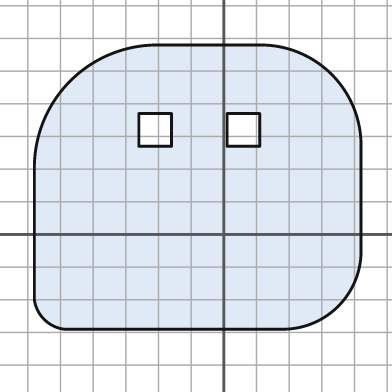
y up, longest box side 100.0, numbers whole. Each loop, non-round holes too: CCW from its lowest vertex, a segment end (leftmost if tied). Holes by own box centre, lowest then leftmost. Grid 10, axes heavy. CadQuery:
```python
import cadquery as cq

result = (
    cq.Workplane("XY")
    .moveTo(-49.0, -29.0)
    .lineTo(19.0, -29.0)
    .threePointArc((35.0, -22.0), (42.0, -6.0))
    .lineTo(42.0, 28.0)
    .threePointArc((33.0, 49.0), (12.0, 58.0))
    .lineTo(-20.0, 58.0)
    .threePointArc((-47.0, 47.0), (-58.0, 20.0))
    .lineTo(-58.0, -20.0)
    .threePointArc((-55.0, -26.0), (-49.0, -29.0))
    .close()
    .moveTo(-26.0, 27.0)
    .lineTo(-16.0, 27.0)
    .lineTo(-16.0, 37.0)
    .lineTo(-26.0, 37.0)
    .close()
    .moveTo(1.0, 27.0)
    .lineTo(11.0, 27.0)
    .lineTo(11.0, 37.0)
    .lineTo(1.0, 37.0)
    .close()
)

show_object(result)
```